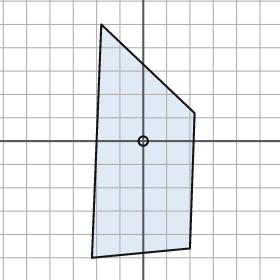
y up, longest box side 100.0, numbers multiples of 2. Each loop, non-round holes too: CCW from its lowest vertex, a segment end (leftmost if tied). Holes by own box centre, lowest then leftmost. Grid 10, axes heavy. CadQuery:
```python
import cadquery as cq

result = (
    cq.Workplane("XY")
    .moveTo(-22.0, -50.0)
    .lineTo(20.0, -46.0)
    .lineTo(22.0, 12.0)
    .lineTo(-18.0, 50.0)
    .close()
    .moveTo(0.0, 0.0)
    .circle(2.0)
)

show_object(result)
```